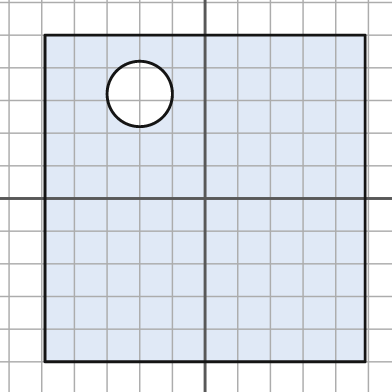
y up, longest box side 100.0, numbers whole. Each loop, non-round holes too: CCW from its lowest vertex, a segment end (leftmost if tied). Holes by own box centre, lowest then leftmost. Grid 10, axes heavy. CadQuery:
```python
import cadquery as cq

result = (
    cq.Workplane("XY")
    .moveTo(-49.0, -50.0)
    .lineTo(49.0, -50.0)
    .lineTo(49.0, 50.0)
    .lineTo(-49.0, 50.0)
    .close()
    .moveTo(-20.0, 32.0)
    .circle(10.0)
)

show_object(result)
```